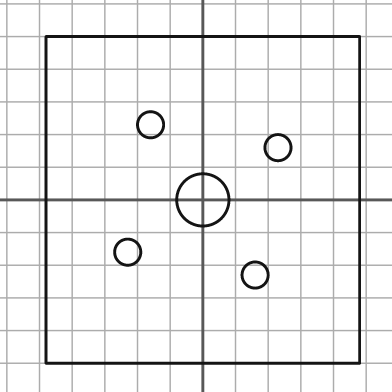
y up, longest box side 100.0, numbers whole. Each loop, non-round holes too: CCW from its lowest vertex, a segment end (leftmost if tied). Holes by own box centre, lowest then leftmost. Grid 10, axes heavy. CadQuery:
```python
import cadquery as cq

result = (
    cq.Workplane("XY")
    .moveTo(-48.0, -50.0)
    .lineTo(48.0, -50.0)
    .lineTo(48.0, 50.0)
    .lineTo(-48.0, 50.0)
    .close()
    .moveTo(16.0, -23.0)
    .circle(4.0)
    .moveTo(-23.0, -16.0)
    .circle(4.0)
    .moveTo(0.0, 0.0)
    .circle(8.0)
    .moveTo(23.0, 16.0)
    .circle(4.0)
    .moveTo(-16.0, 23.0)
    .circle(4.0)
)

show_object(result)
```